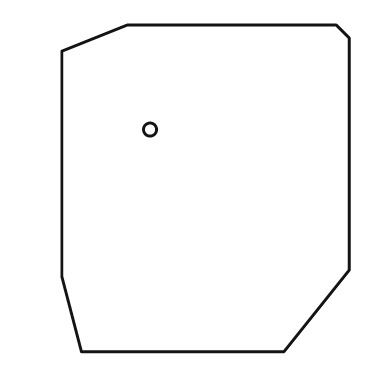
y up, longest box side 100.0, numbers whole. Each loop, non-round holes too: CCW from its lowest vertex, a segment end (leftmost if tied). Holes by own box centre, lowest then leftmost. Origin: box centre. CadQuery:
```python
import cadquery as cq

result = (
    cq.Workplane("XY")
    .moveTo(-38.0, -50.0)
    .lineTo(24.0, -50.0)
    .lineTo(44.0, -25.0)
    .lineTo(44.0, 46.0)
    .lineTo(40.0, 50.0)
    .lineTo(-24.0, 50.0)
    .lineTo(-44.0, 42.0)
    .lineTo(-44.0, -27.0)
    .close()
    .moveTo(-17.0, 18.0)
    .circle(2.0)
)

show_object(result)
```